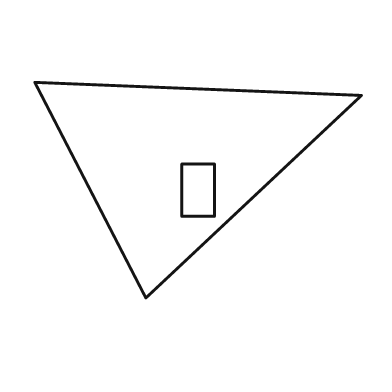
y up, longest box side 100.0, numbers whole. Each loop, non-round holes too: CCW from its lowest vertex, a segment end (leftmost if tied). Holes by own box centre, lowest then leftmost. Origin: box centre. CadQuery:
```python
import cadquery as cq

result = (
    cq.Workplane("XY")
    .moveTo(-16.0, -33.0)
    .lineTo(50.0, 29.0)
    .lineTo(-50.0, 33.0)
    .close()
    .moveTo(-5.0, -8.0)
    .lineTo(5.0, -8.0)
    .lineTo(5.0, 8.0)
    .lineTo(-5.0, 8.0)
    .close()
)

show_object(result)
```